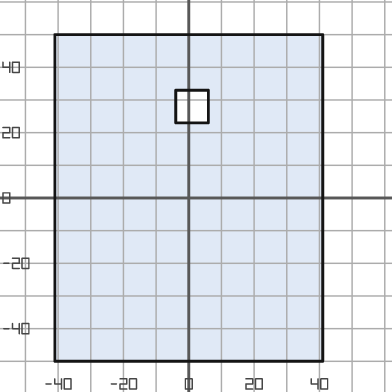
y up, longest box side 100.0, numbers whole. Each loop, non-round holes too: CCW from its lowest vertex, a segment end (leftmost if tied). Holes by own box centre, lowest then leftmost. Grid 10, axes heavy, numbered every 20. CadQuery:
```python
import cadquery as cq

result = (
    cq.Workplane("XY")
    .moveTo(-41.0, -50.0)
    .lineTo(41.0, -50.0)
    .lineTo(41.0, 50.0)
    .lineTo(-41.0, 50.0)
    .close()
    .moveTo(-4.0, 23.0)
    .lineTo(6.0, 23.0)
    .lineTo(6.0, 33.0)
    .lineTo(-4.0, 33.0)
    .close()
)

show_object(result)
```